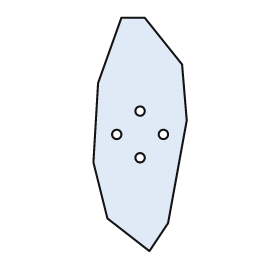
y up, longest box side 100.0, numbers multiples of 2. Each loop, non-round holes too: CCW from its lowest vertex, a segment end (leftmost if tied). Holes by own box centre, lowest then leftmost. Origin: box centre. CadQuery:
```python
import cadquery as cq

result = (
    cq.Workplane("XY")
    .moveTo(4.0, -50.0)
    .lineTo(12.0, -38.0)
    .lineTo(20.0, 6.0)
    .lineTo(18.0, 30.0)
    .lineTo(2.0, 50.0)
    .lineTo(-8.0, 50.0)
    .lineTo(-18.0, 22.0)
    .lineTo(-20.0, -12.0)
    .lineTo(-14.0, -36.0)
    .close()
    .moveTo(0.0, -10.0)
    .circle(2.0)
    .moveTo(-10.0, 0.0)
    .circle(2.0)
    .moveTo(10.0, 0.0)
    .circle(2.0)
    .moveTo(0.0, 10.0)
    .circle(2.0)
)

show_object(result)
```